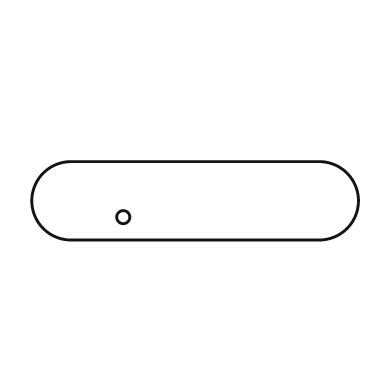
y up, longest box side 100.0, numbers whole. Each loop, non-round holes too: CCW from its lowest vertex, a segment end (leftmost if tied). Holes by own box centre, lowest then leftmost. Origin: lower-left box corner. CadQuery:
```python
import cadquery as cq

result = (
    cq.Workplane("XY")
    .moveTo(12.0, 0.0)
    .lineTo(88.0, 0.0)
    .threePointArc((100.0, 12.0), (88.0, 24.0))
    .lineTo(12.0, 24.0)
    .threePointArc((0.0, 12.0), (12.0, 0.0))
    .close()
    .moveTo(28.0, 7.0)
    .circle(2.0)
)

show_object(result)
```